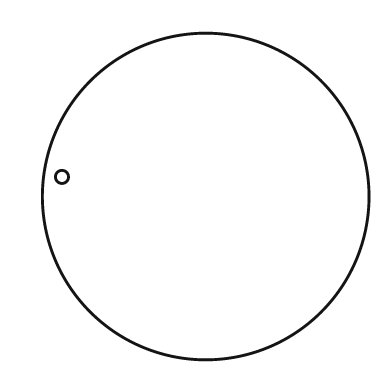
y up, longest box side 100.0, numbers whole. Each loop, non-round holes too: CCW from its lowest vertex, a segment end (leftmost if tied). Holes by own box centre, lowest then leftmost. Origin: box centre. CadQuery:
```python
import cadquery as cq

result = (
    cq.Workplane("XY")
    .moveTo(0.0, 0.0)
    .circle(50.0)
    .moveTo(-44.0, 6.0)
    .circle(2.0)
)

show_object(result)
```